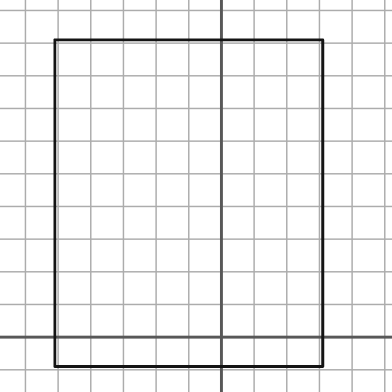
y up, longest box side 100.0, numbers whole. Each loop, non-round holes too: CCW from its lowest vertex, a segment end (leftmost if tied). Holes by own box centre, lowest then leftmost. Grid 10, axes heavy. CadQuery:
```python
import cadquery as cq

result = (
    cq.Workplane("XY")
    .moveTo(-51.0, -9.0)
    .lineTo(31.0, -9.0)
    .lineTo(31.0, 91.0)
    .lineTo(-51.0, 91.0)
    .close()
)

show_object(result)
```